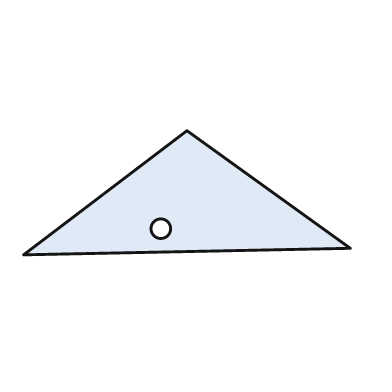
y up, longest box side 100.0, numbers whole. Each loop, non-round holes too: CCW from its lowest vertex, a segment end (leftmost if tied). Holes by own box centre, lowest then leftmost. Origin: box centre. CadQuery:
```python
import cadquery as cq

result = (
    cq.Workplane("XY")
    .moveTo(-50.0, -19.0)
    .lineTo(50.0, -17.0)
    .lineTo(0.0, 19.0)
    .close()
    .moveTo(-8.0, -11.0)
    .circle(3.0)
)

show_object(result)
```